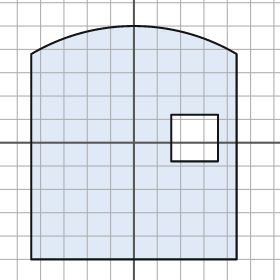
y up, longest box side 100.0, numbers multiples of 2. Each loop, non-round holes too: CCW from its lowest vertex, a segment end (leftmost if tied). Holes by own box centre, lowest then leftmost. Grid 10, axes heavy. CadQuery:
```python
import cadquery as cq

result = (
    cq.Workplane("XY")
    .moveTo(-44.0, -50.0)
    .lineTo(44.0, -50.0)
    .lineTo(44.0, 38.0)
    .threePointArc((0.0, 50.0), (-44.0, 38.0))
    .close()
    .moveTo(16.0, -8.0)
    .lineTo(36.0, -8.0)
    .lineTo(36.0, 12.0)
    .lineTo(16.0, 12.0)
    .close()
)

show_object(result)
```